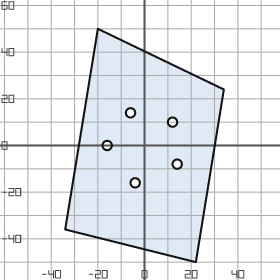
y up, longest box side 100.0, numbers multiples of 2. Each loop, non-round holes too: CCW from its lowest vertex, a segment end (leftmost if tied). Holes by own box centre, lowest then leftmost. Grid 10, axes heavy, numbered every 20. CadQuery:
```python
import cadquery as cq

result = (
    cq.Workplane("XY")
    .moveTo(22.0, -50.0)
    .lineTo(34.0, 24.0)
    .lineTo(-20.0, 50.0)
    .lineTo(-34.0, -36.0)
    .close()
    .moveTo(-4.0, -16.0)
    .circle(2.0)
    .moveTo(14.0, -8.0)
    .circle(2.0)
    .moveTo(-16.0, 0.0)
    .circle(2.0)
    .moveTo(12.0, 10.0)
    .circle(2.0)
    .moveTo(-6.0, 14.0)
    .circle(2.0)
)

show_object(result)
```